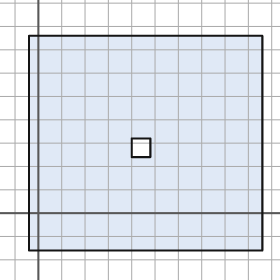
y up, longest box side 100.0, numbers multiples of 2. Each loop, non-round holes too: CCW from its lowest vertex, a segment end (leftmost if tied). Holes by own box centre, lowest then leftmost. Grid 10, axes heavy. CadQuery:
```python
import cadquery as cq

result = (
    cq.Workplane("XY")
    .moveTo(-4.0, -16.0)
    .lineTo(96.0, -16.0)
    .lineTo(96.0, 76.0)
    .lineTo(-4.0, 76.0)
    .close()
    .moveTo(40.0, 24.0)
    .lineTo(48.0, 24.0)
    .lineTo(48.0, 32.0)
    .lineTo(40.0, 32.0)
    .close()
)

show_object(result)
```